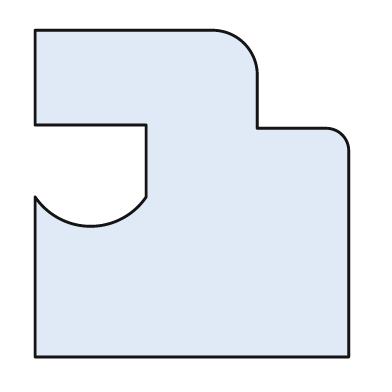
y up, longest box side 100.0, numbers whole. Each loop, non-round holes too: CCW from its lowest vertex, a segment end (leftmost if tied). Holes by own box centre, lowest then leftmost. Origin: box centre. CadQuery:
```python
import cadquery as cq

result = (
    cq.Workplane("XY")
    .moveTo(-48.0, -50.0)
    .lineTo(48.0, -50.0)
    .lineTo(48.0, 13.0)
    .threePointArc((46.0, 18.0), (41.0, 20.0))
    .lineTo(20.0, 20.0)
    .lineTo(20.0, 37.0)
    .threePointArc((16.0, 46.0), (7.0, 50.0))
    .lineTo(-48.0, 50.0)
    .lineTo(-48.0, 21.0)
    .lineTo(-14.0, 21.0)
    .lineTo(-14.0, -1.0)
    .threePointArc((-31.0, -10.0), (-48.0, -1.0))
    .close()
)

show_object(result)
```